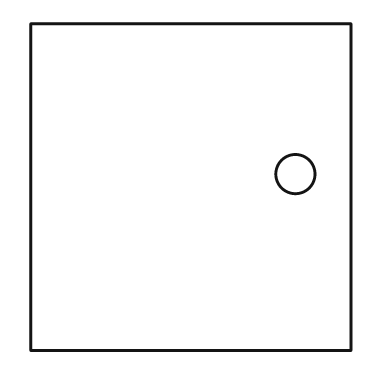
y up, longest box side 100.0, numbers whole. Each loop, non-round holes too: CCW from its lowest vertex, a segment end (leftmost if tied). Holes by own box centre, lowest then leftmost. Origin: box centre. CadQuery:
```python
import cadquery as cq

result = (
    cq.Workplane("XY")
    .moveTo(-49.0, -50.0)
    .lineTo(49.0, -50.0)
    .lineTo(49.0, 50.0)
    .lineTo(-49.0, 50.0)
    .close()
    .moveTo(32.0, 4.0)
    .circle(6.0)
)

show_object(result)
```